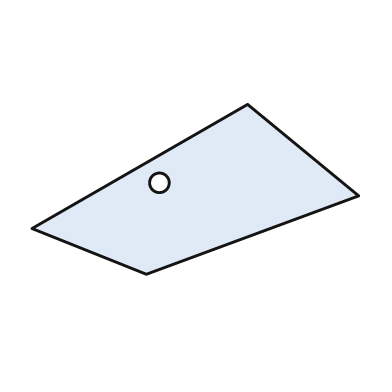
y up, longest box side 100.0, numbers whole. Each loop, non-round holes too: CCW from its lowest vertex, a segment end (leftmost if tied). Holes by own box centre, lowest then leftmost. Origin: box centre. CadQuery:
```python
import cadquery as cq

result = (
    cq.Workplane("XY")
    .moveTo(-15.0, -26.0)
    .lineTo(50.0, -2.0)
    .lineTo(16.0, 26.0)
    .lineTo(-50.0, -12.0)
    .close()
    .moveTo(-11.0, 2.0)
    .circle(3.0)
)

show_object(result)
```